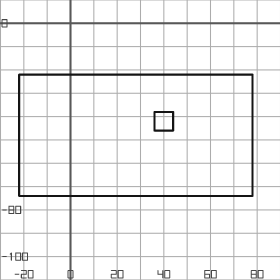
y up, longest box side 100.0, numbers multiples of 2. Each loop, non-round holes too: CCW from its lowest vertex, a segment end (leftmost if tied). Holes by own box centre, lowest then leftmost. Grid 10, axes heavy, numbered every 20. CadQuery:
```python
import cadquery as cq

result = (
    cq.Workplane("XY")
    .moveTo(-22.0, -74.0)
    .lineTo(78.0, -74.0)
    .lineTo(78.0, -22.0)
    .lineTo(-22.0, -22.0)
    .close()
    .moveTo(36.0, -46.0)
    .lineTo(44.0, -46.0)
    .lineTo(44.0, -38.0)
    .lineTo(36.0, -38.0)
    .close()
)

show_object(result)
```